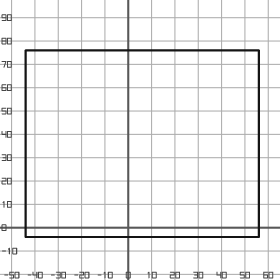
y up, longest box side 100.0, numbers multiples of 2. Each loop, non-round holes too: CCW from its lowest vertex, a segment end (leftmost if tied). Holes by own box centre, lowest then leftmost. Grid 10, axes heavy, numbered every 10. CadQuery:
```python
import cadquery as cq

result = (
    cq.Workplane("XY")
    .moveTo(-44.0, -4.0)
    .lineTo(56.0, -4.0)
    .lineTo(56.0, 76.0)
    .lineTo(-44.0, 76.0)
    .close()
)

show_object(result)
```